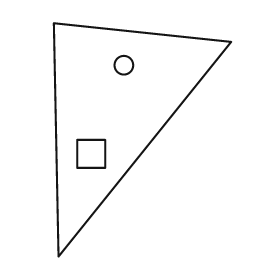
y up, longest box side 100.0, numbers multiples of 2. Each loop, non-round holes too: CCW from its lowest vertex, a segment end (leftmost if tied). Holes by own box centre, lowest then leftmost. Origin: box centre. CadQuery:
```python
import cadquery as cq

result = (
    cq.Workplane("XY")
    .moveTo(-36.0, -50.0)
    .lineTo(38.0, 42.0)
    .lineTo(-38.0, 50.0)
    .close()
    .moveTo(-28.0, -12.0)
    .lineTo(-16.0, -12.0)
    .lineTo(-16.0, 0.0)
    .lineTo(-28.0, 0.0)
    .close()
    .moveTo(-8.0, 32.0)
    .circle(4.0)
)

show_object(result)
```